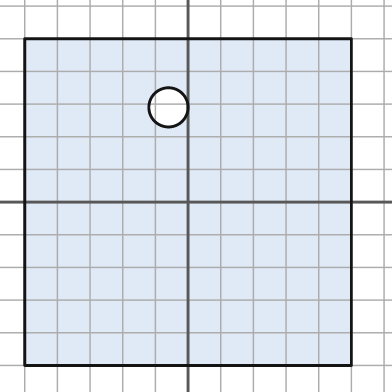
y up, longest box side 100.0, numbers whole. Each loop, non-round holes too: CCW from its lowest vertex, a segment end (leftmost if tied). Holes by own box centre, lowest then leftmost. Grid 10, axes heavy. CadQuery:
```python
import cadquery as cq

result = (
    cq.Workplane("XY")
    .moveTo(-50.0, -50.0)
    .lineTo(50.0, -50.0)
    .lineTo(50.0, 50.0)
    .lineTo(-50.0, 50.0)
    .close()
    .moveTo(-6.0, 29.0)
    .circle(6.0)
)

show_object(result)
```